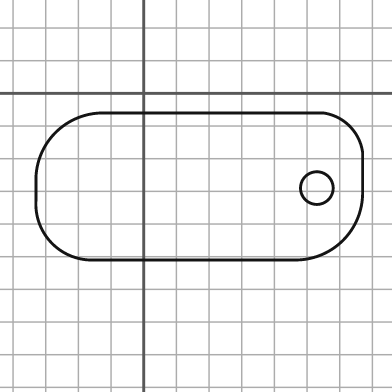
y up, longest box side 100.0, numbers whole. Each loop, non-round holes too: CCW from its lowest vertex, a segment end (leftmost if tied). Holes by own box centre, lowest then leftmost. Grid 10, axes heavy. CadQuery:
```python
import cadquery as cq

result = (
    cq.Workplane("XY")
    .moveTo(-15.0, -51.0)
    .lineTo(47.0, -51.0)
    .threePointArc((61.0, -45.0), (67.0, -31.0))
    .lineTo(67.0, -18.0)
    .threePointArc((63.0, -10.0), (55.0, -6.0))
    .lineTo(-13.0, -6.0)
    .threePointArc((-27.0, -12.0), (-33.0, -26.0))
    .lineTo(-33.0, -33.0)
    .threePointArc((-28.0, -46.0), (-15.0, -51.0))
    .close()
    .moveTo(53.0, -29.0)
    .circle(5.0)
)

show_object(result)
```